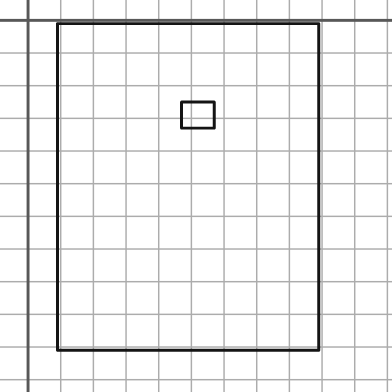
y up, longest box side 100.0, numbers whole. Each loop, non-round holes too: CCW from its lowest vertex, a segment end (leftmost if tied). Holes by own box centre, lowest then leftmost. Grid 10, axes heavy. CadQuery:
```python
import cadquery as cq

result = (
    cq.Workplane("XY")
    .moveTo(9.0, -101.0)
    .lineTo(89.0, -101.0)
    .lineTo(89.0, -1.0)
    .lineTo(9.0, -1.0)
    .close()
    .moveTo(47.0, -33.0)
    .lineTo(57.0, -33.0)
    .lineTo(57.0, -25.0)
    .lineTo(47.0, -25.0)
    .close()
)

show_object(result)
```